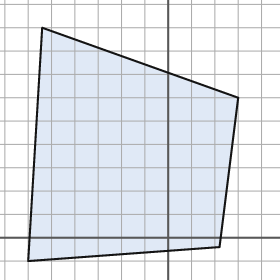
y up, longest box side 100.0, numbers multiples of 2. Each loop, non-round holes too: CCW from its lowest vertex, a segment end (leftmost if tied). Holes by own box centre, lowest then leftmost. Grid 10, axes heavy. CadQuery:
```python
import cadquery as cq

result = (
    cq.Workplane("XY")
    .moveTo(-60.0, -10.0)
    .lineTo(22.0, -4.0)
    .lineTo(30.0, 60.0)
    .lineTo(-54.0, 90.0)
    .close()
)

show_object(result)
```